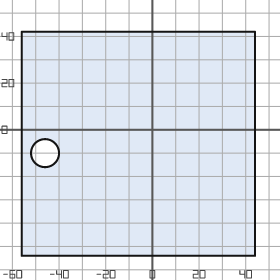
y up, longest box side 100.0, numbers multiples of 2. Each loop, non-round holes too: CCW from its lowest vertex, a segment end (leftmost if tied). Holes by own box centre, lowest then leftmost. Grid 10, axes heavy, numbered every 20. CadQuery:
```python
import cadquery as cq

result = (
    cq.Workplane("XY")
    .moveTo(-56.0, -54.0)
    .lineTo(44.0, -54.0)
    .lineTo(44.0, 42.0)
    .lineTo(-56.0, 42.0)
    .close()
    .moveTo(-46.0, -10.0)
    .circle(6.0)
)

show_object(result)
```